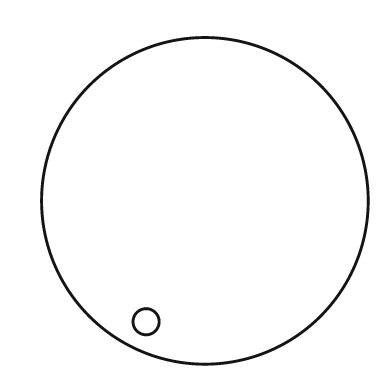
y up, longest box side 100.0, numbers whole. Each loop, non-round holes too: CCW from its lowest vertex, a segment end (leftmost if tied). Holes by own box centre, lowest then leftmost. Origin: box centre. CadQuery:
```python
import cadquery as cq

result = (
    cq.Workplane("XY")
    .moveTo(0.0, 0.0)
    .circle(50.0)
    .moveTo(-18.0, -37.0)
    .circle(4.0)
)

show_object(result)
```